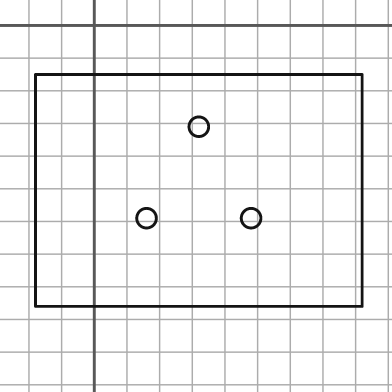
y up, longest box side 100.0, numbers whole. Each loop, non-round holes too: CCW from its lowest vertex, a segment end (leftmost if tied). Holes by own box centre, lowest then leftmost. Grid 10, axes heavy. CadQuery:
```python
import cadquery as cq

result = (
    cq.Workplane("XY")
    .moveTo(-18.0, -86.0)
    .lineTo(82.0, -86.0)
    .lineTo(82.0, -15.0)
    .lineTo(-18.0, -15.0)
    .close()
    .moveTo(16.0, -59.0)
    .circle(3.0)
    .moveTo(48.0, -59.0)
    .circle(3.0)
    .moveTo(32.0, -31.0)
    .circle(3.0)
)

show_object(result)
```